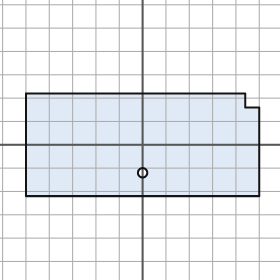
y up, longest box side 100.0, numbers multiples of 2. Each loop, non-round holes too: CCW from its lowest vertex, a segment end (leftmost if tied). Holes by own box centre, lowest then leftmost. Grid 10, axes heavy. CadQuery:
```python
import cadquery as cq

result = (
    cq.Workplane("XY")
    .moveTo(-50.0, -22.0)
    .lineTo(50.0, -22.0)
    .lineTo(50.0, 16.0)
    .lineTo(44.0, 16.0)
    .lineTo(44.0, 22.0)
    .lineTo(-50.0, 22.0)
    .close()
    .moveTo(0.0, -12.0)
    .circle(2.0)
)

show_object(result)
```